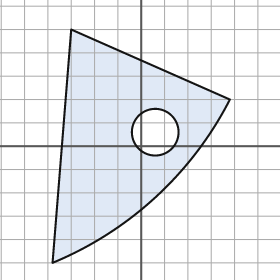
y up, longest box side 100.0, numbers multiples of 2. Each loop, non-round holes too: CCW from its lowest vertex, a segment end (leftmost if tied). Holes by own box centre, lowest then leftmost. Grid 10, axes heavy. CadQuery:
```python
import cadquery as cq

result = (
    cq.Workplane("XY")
    .moveTo(-38.0, -50.0)
    .threePointArc((6.0, -22.0), (38.0, 20.0))
    .lineTo(-30.0, 50.0)
    .close()
    .moveTo(6.0, 6.0)
    .circle(10.0)
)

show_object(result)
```